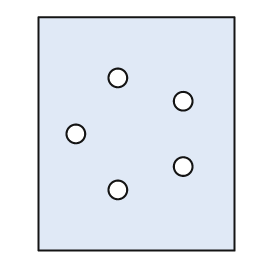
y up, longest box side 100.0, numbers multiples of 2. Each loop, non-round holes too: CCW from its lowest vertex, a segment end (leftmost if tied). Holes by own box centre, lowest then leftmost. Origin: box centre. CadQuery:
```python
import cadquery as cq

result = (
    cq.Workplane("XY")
    .moveTo(-42.0, -50.0)
    .lineTo(42.0, -50.0)
    .lineTo(42.0, 50.0)
    .lineTo(-42.0, 50.0)
    .close()
    .moveTo(-8.0, -24.0)
    .circle(4.0)
    .moveTo(20.0, -14.0)
    .circle(4.0)
    .moveTo(-26.0, 0.0)
    .circle(4.0)
    .moveTo(20.0, 14.0)
    .circle(4.0)
    .moveTo(-8.0, 24.0)
    .circle(4.0)
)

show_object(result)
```